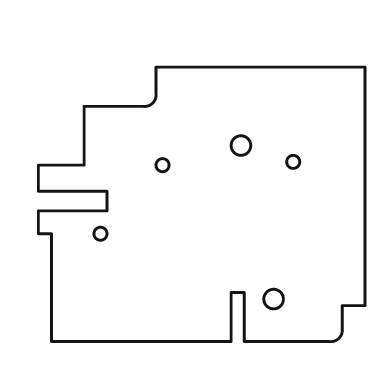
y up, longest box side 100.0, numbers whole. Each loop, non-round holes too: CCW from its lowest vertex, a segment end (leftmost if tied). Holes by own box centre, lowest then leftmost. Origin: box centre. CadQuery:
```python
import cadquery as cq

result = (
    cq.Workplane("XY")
    .moveTo(-46.0, -42.0)
    .lineTo(9.0, -42.0)
    .lineTo(9.0, -27.0)
    .lineTo(13.0, -27.0)
    .lineTo(13.0, -42.0)
    .lineTo(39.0, -42.0)
    .threePointArc((42.0, -41.0), (43.0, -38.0))
    .lineTo(43.0, -31.0)
    .lineTo(50.0, -31.0)
    .lineTo(50.0, 42.0)
    .lineTo(-14.0, 42.0)
    .lineTo(-14.0, 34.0)
    .threePointArc((-15.0, 31.0), (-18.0, 30.0))
    .lineTo(-36.0, 30.0)
    .lineTo(-36.0, 12.0)
    .lineTo(-50.0, 12.0)
    .lineTo(-50.0, 4.0)
    .lineTo(-29.0, 4.0)
    .lineTo(-29.0, -2.0)
    .lineTo(-50.0, -2.0)
    .lineTo(-50.0, -9.0)
    .lineTo(-46.0, -9.0)
    .close()
    .moveTo(22.0, -29.0)
    .circle(3.0)
    .moveTo(-31.0, -9.0)
    .circle(2.0)
    .moveTo(-12.0, 12.0)
    .circle(2.0)
    .moveTo(28.0, 13.0)
    .circle(2.0)
    .moveTo(12.0, 18.0)
    .circle(3.0)
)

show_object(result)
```